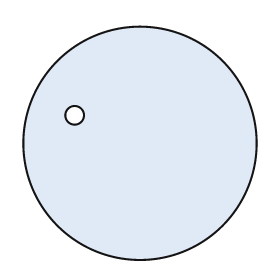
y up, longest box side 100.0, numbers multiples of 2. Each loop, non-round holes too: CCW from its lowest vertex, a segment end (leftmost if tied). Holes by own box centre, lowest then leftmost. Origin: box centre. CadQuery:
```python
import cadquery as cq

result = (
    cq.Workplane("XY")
    .moveTo(0.0, 0.0)
    .circle(50.0)
    .moveTo(-28.0, 12.0)
    .circle(4.0)
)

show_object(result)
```